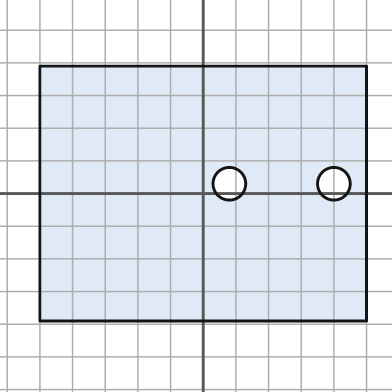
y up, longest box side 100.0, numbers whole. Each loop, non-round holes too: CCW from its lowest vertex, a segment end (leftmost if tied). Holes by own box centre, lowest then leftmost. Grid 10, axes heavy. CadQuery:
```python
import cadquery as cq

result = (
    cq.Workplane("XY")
    .moveTo(-50.0, -39.0)
    .lineTo(50.0, -39.0)
    .lineTo(50.0, 39.0)
    .lineTo(-50.0, 39.0)
    .close()
    .moveTo(8.0, 3.0)
    .circle(5.0)
    .moveTo(40.0, 3.0)
    .circle(5.0)
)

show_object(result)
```